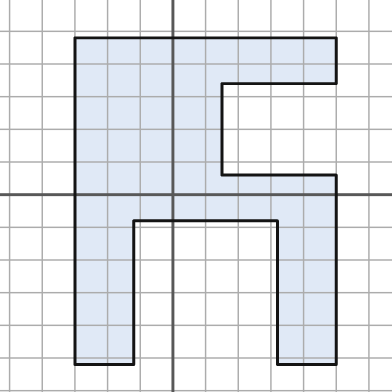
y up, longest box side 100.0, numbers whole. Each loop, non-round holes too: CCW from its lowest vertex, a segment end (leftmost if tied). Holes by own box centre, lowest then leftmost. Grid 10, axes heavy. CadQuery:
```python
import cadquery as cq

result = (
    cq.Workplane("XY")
    .moveTo(-30.0, -52.0)
    .lineTo(-12.0, -52.0)
    .lineTo(-12.0, -8.0)
    .lineTo(32.0, -8.0)
    .lineTo(32.0, -52.0)
    .lineTo(50.0, -52.0)
    .lineTo(50.0, 6.0)
    .lineTo(15.0, 6.0)
    .lineTo(15.0, 34.0)
    .lineTo(50.0, 34.0)
    .lineTo(50.0, 48.0)
    .lineTo(-30.0, 48.0)
    .close()
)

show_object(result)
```